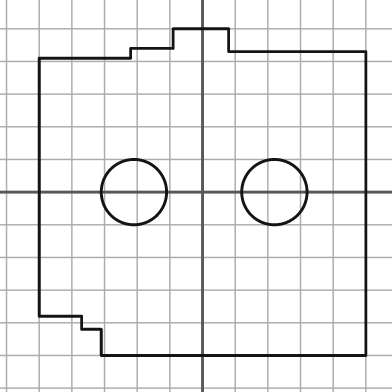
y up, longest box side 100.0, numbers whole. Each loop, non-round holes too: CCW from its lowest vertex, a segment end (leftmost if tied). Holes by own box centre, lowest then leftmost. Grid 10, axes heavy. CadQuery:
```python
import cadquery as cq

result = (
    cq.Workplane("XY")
    .moveTo(-31.0, -50.0)
    .lineTo(50.0, -50.0)
    .lineTo(50.0, 43.0)
    .lineTo(8.0, 43.0)
    .lineTo(8.0, 50.0)
    .lineTo(-9.0, 50.0)
    .lineTo(-9.0, 44.0)
    .lineTo(-22.0, 44.0)
    .lineTo(-22.0, 41.0)
    .lineTo(-50.0, 41.0)
    .lineTo(-50.0, -38.0)
    .lineTo(-37.0, -38.0)
    .lineTo(-37.0, -42.0)
    .lineTo(-31.0, -42.0)
    .close()
    .moveTo(-21.0, 0.0)
    .circle(10.0)
    .moveTo(22.0, 0.0)
    .circle(10.0)
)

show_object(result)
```